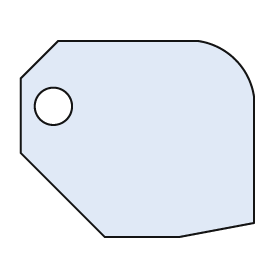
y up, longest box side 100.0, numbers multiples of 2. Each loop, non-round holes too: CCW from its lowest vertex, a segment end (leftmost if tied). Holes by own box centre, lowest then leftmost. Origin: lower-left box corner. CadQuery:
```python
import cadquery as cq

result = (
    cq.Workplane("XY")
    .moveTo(36.0, 0.0)
    .lineTo(68.0, 0.0)
    .lineTo(100.0, 6.0)
    .lineTo(100.0, 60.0)
    .threePointArc((92.0, 76.0), (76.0, 84.0))
    .lineTo(16.0, 84.0)
    .lineTo(0.0, 68.0)
    .lineTo(0.0, 36.0)
    .close()
    .moveTo(14.0, 56.0)
    .circle(8.0)
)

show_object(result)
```